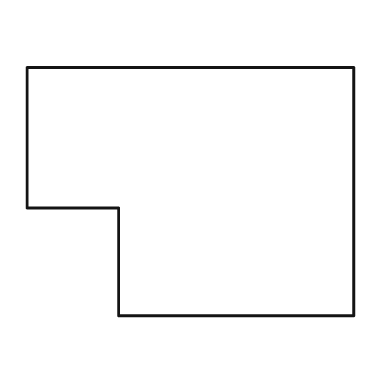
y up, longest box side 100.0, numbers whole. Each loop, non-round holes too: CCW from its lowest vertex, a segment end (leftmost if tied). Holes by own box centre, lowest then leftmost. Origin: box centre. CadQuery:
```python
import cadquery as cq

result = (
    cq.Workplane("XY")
    .moveTo(-22.0, -38.0)
    .lineTo(50.0, -38.0)
    .lineTo(50.0, 38.0)
    .lineTo(-50.0, 38.0)
    .lineTo(-50.0, -5.0)
    .lineTo(-22.0, -5.0)
    .close()
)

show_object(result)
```